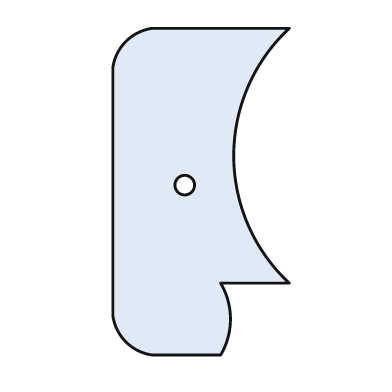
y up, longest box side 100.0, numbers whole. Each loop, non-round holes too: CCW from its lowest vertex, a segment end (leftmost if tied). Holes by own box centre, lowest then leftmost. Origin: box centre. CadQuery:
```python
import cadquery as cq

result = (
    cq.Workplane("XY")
    .moveTo(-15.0, -50.0)
    .lineTo(6.0, -50.0)
    .threePointArc((9.0, -39.0), (6.0, -28.0))
    .lineTo(27.0, -28.0)
    .threePointArc((10.0, 11.0), (27.0, 50.0))
    .lineTo(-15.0, 50.0)
    .threePointArc((-23.0, 46.0), (-27.0, 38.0))
    .lineTo(-27.0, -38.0)
    .threePointArc((-23.0, -46.0), (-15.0, -50.0))
    .close()
    .moveTo(-5.0, 2.0)
    .circle(3.0)
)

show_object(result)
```